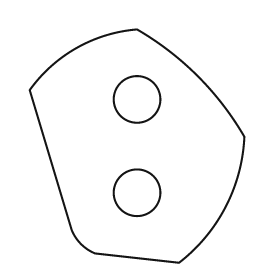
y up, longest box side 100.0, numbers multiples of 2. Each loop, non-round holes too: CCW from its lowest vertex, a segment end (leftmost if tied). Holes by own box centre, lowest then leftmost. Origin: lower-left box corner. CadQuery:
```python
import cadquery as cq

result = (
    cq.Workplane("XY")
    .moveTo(64.0, 0.0)
    .threePointArc((84.0, 24.0), (92.0, 54.0))
    .threePointArc((72.0, 80.0), (46.0, 100.0))
    .threePointArc((20.0, 92.0), (0.0, 74.0))
    .lineTo(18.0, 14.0)
    .threePointArc((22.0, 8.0), (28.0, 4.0))
    .close()
    .moveTo(46.0, 30.0)
    .circle(10.0)
    .moveTo(46.0, 70.0)
    .circle(10.0)
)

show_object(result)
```